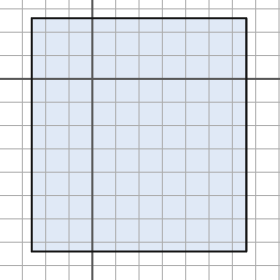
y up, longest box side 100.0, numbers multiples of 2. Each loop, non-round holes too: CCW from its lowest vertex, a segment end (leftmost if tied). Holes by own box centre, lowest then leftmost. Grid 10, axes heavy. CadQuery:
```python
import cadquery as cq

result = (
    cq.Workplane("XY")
    .moveTo(-26.0, -74.0)
    .lineTo(66.0, -74.0)
    .lineTo(66.0, 26.0)
    .lineTo(-26.0, 26.0)
    .close()
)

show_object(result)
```